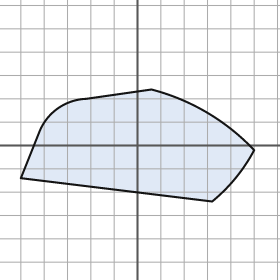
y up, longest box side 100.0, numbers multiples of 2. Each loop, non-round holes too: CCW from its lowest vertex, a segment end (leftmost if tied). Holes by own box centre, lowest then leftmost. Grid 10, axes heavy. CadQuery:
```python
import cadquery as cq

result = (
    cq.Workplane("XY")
    .moveTo(32.0, -24.0)
    .threePointArc((42.0, -14.0), (50.0, -2.0))
    .threePointArc((30.0, 14.0), (6.0, 24.0))
    .lineTo(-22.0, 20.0)
    .threePointArc((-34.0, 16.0), (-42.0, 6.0))
    .lineTo(-50.0, -14.0)
    .close()
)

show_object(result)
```